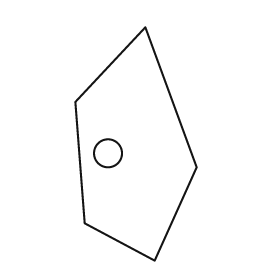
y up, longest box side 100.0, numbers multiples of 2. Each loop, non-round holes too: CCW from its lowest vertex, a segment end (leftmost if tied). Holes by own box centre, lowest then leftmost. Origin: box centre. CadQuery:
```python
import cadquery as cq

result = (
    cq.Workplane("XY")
    .moveTo(8.0, -50.0)
    .lineTo(26.0, -10.0)
    .lineTo(4.0, 50.0)
    .lineTo(-26.0, 18.0)
    .lineTo(-22.0, -34.0)
    .close()
    .moveTo(-12.0, -4.0)
    .circle(6.0)
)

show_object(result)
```